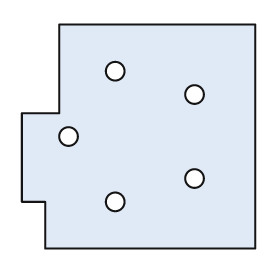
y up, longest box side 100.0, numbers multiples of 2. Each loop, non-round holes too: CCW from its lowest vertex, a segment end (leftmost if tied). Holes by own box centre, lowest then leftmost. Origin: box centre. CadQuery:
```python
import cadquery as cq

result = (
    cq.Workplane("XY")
    .moveTo(-40.0, -48.0)
    .lineTo(50.0, -48.0)
    .lineTo(50.0, 48.0)
    .lineTo(-34.0, 48.0)
    .lineTo(-34.0, 10.0)
    .lineTo(-50.0, 10.0)
    .lineTo(-50.0, -28.0)
    .lineTo(-40.0, -28.0)
    .close()
    .moveTo(-10.0, -28.0)
    .circle(4.0)
    .moveTo(24.0, -18.0)
    .circle(4.0)
    .moveTo(-30.0, 0.0)
    .circle(4.0)
    .moveTo(24.0, 18.0)
    .circle(4.0)
    .moveTo(-10.0, 28.0)
    .circle(4.0)
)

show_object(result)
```